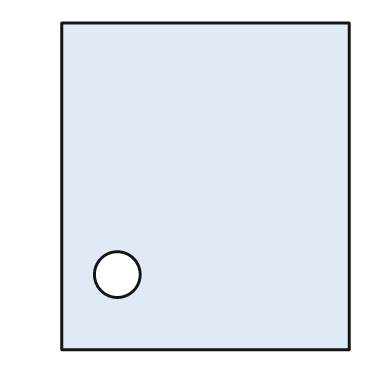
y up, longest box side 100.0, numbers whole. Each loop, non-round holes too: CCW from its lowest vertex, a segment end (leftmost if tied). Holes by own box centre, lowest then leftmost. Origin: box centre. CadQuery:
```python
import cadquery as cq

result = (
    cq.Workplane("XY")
    .moveTo(-44.0, -50.0)
    .lineTo(44.0, -50.0)
    .lineTo(44.0, 50.0)
    .lineTo(-44.0, 50.0)
    .close()
    .moveTo(-27.0, -27.0)
    .circle(7.0)
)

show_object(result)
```